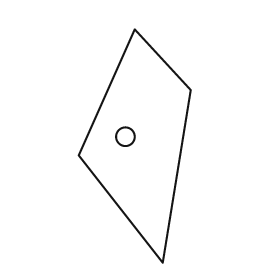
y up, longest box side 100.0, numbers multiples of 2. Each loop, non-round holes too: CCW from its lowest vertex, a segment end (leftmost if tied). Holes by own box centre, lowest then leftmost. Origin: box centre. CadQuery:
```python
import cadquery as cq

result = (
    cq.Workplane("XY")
    .moveTo(12.0, -50.0)
    .lineTo(24.0, 24.0)
    .lineTo(0.0, 50.0)
    .lineTo(-24.0, -4.0)
    .close()
    .moveTo(-4.0, 4.0)
    .circle(4.0)
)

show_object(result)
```